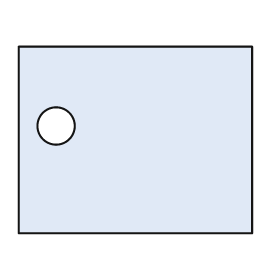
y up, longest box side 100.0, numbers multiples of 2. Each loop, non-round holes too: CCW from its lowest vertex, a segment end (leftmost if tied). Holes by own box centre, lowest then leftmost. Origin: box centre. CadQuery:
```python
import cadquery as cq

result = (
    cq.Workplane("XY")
    .moveTo(-50.0, -40.0)
    .lineTo(50.0, -40.0)
    .lineTo(50.0, 40.0)
    .lineTo(-50.0, 40.0)
    .close()
    .moveTo(-34.0, 6.0)
    .circle(8.0)
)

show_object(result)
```